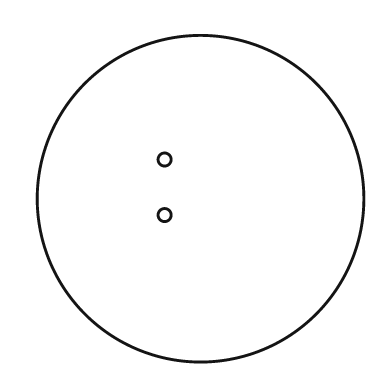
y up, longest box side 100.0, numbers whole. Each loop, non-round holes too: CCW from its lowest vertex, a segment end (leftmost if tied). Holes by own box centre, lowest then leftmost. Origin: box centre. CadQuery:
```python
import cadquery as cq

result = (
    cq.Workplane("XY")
    .moveTo(0.0, 0.0)
    .circle(50.0)
    .moveTo(-11.0, -5.0)
    .circle(2.0)
    .moveTo(-11.0, 12.0)
    .circle(2.0)
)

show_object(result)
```